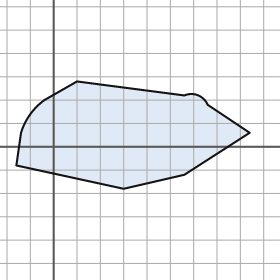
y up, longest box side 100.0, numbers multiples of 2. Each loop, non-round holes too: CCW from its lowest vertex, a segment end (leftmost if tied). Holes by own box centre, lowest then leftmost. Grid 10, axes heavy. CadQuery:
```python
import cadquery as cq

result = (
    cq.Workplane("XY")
    .moveTo(30.0, -18.0)
    .lineTo(56.0, -12.0)
    .lineTo(84.0, 6.0)
    .lineTo(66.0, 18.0)
    .threePointArc((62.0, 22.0), (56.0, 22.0))
    .lineTo(10.0, 28.0)
    .lineTo(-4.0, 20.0)
    .threePointArc((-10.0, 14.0), (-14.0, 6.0))
    .lineTo(-16.0, -8.0)
    .close()
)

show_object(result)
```